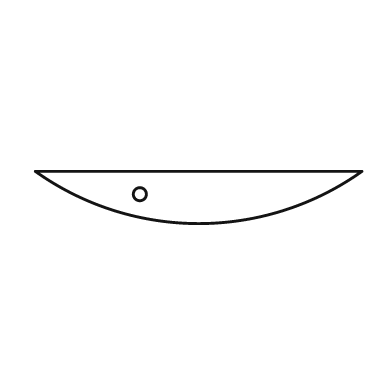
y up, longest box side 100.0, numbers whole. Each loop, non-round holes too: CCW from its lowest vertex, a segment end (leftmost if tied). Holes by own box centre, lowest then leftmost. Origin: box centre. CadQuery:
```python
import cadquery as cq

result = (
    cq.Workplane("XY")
    .moveTo(-50.0, 8.0)
    .threePointArc((0.0, -8.0), (50.0, 8.0))
    .close()
    .moveTo(-18.0, 1.0)
    .circle(2.0)
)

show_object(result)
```